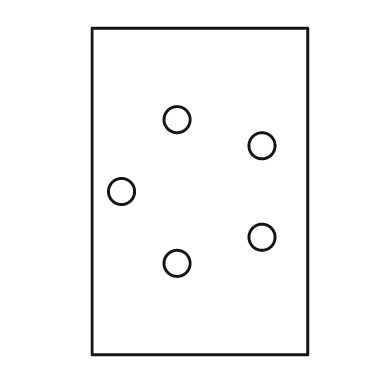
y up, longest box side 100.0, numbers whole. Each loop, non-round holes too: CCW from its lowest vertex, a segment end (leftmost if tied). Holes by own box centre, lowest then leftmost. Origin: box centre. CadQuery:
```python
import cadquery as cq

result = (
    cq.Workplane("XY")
    .moveTo(-33.0, -50.0)
    .lineTo(33.0, -50.0)
    .lineTo(33.0, 50.0)
    .lineTo(-33.0, 50.0)
    .close()
    .moveTo(-7.0, -22.0)
    .circle(4.0)
    .moveTo(19.0, -14.0)
    .circle(4.0)
    .moveTo(-24.0, 0.0)
    .circle(4.0)
    .moveTo(19.0, 14.0)
    .circle(4.0)
    .moveTo(-7.0, 22.0)
    .circle(4.0)
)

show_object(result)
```